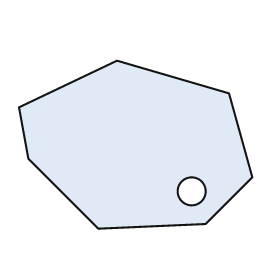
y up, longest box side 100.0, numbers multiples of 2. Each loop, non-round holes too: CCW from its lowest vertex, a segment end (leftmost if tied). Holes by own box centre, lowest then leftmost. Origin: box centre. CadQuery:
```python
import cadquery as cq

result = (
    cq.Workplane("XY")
    .moveTo(-16.0, -36.0)
    .lineTo(30.0, -34.0)
    .lineTo(50.0, -14.0)
    .lineTo(40.0, 22.0)
    .lineTo(-8.0, 36.0)
    .lineTo(-50.0, 16.0)
    .lineTo(-46.0, -6.0)
    .close()
    .moveTo(24.0, -20.0)
    .circle(6.0)
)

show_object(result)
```